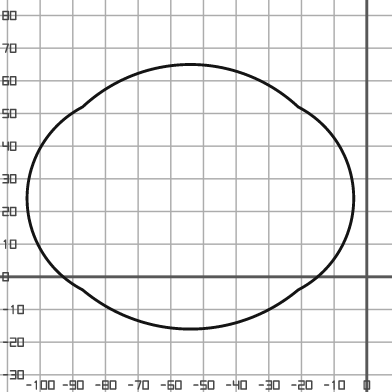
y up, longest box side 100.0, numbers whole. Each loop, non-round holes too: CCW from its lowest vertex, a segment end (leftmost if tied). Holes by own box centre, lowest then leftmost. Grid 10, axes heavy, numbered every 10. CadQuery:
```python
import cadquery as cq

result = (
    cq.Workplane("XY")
    .moveTo(-87.0, -4.0)
    .threePointArc((-54.0, -16.0), (-21.0, -4.0))
    .threePointArc((-4.0, 24.0), (-21.0, 52.0))
    .threePointArc((-54.0, 65.0), (-87.0, 52.0))
    .threePointArc((-104.0, 24.0), (-87.0, -4.0))
    .close()
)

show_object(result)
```